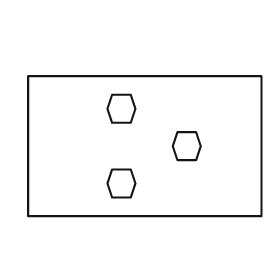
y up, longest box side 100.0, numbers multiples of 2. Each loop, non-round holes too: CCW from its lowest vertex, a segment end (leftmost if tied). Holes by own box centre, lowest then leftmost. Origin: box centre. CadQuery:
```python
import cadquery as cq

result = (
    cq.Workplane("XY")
    .moveTo(-50.0, -30.0)
    .lineTo(50.0, -30.0)
    .lineTo(50.0, 30.0)
    .lineTo(-50.0, 30.0)
    .close()
    .moveTo(-14.0, -22.0)
    .lineTo(-6.0, -22.0)
    .lineTo(-4.0, -16.0)
    .lineTo(-6.0, -10.0)
    .lineTo(-14.0, -10.0)
    .lineTo(-16.0, -16.0)
    .close()
    .moveTo(14.0, -6.0)
    .lineTo(22.0, -6.0)
    .lineTo(24.0, 0.0)
    .lineTo(22.0, 6.0)
    .lineTo(14.0, 6.0)
    .lineTo(12.0, 0.0)
    .close()
    .moveTo(-14.0, 10.0)
    .lineTo(-6.0, 10.0)
    .lineTo(-4.0, 16.0)
    .lineTo(-6.0, 22.0)
    .lineTo(-14.0, 22.0)
    .lineTo(-16.0, 16.0)
    .close()
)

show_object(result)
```